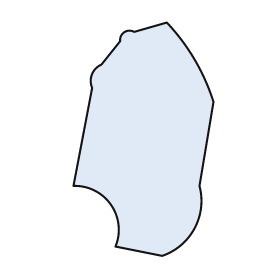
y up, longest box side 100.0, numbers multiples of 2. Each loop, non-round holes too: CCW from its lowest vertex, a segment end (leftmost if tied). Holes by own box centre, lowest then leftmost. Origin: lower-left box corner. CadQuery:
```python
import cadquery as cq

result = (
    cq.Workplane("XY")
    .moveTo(38.0, 0.0)
    .threePointArc((52.0, 12.0), (54.0, 30.0))
    .lineTo(60.0, 66.0)
    .threePointArc((52.0, 84.0), (40.0, 100.0))
    .lineTo(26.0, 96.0)
    .threePointArc((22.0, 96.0), (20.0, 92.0))
    .lineTo(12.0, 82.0)
    .threePointArc((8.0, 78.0), (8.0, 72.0))
    .lineTo(0.0, 30.0)
    .threePointArc((16.0, 22.0), (18.0, 4.0))
    .close()
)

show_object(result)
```